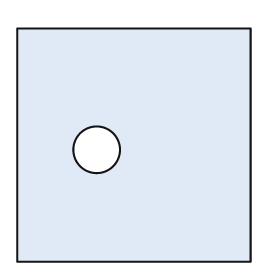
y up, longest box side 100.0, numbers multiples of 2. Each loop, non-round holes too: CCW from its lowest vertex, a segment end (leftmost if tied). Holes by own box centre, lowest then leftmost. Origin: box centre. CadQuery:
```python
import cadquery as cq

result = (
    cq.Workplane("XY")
    .moveTo(-50.0, -50.0)
    .lineTo(50.0, -50.0)
    .lineTo(50.0, 50.0)
    .lineTo(-50.0, 50.0)
    .close()
    .moveTo(-16.0, -2.0)
    .circle(10.0)
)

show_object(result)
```